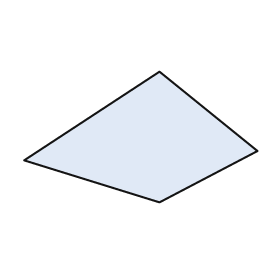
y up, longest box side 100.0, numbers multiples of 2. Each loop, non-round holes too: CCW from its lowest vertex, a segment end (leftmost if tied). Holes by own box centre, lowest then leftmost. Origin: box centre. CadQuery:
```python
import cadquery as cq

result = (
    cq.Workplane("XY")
    .moveTo(8.0, -28.0)
    .lineTo(50.0, -6.0)
    .lineTo(8.0, 28.0)
    .lineTo(-50.0, -10.0)
    .close()
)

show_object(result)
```